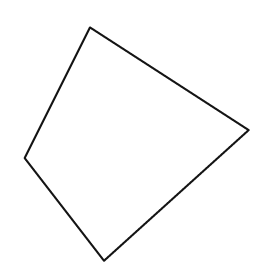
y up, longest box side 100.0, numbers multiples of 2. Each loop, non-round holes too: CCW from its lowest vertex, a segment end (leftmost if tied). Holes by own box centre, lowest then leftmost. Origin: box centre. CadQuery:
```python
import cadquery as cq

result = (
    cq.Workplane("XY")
    .moveTo(-14.0, -50.0)
    .lineTo(48.0, 6.0)
    .lineTo(-20.0, 50.0)
    .lineTo(-48.0, -6.0)
    .close()
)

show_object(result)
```